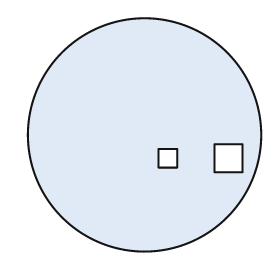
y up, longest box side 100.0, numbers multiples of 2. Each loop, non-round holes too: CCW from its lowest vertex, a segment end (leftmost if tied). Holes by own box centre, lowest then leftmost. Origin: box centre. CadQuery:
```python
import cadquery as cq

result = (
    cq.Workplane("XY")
    .moveTo(0.0, 0.0)
    .circle(50.0)
    .moveTo(6.0, -14.0)
    .lineTo(14.0, -14.0)
    .lineTo(14.0, -6.0)
    .lineTo(6.0, -6.0)
    .close()
    .moveTo(30.0, -16.0)
    .lineTo(42.0, -16.0)
    .lineTo(42.0, -4.0)
    .lineTo(30.0, -4.0)
    .close()
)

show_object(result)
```